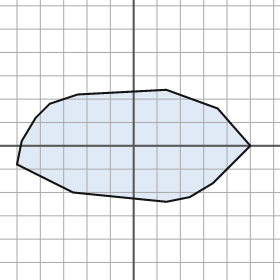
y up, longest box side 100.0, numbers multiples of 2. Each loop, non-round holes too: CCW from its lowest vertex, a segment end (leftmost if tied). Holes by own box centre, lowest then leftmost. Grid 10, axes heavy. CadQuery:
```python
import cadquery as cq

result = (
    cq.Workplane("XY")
    .moveTo(14.0, -24.0)
    .lineTo(24.0, -22.0)
    .lineTo(34.0, -16.0)
    .lineTo(50.0, 0.0)
    .lineTo(36.0, 16.0)
    .lineTo(14.0, 24.0)
    .lineTo(-24.0, 22.0)
    .lineTo(-36.0, 18.0)
    .lineTo(-42.0, 12.0)
    .lineTo(-48.0, 2.0)
    .lineTo(-50.0, -8.0)
    .lineTo(-26.0, -20.0)
    .close()
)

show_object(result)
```